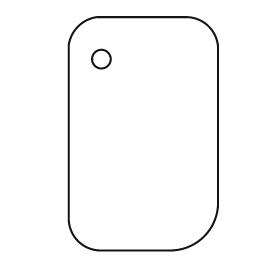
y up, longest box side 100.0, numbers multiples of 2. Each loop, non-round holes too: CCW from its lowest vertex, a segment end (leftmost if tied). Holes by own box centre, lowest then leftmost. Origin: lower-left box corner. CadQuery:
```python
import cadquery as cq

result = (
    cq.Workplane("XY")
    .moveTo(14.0, 0.0)
    .lineTo(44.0, 0.0)
    .threePointArc((58.0, 6.0), (64.0, 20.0))
    .lineTo(64.0, 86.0)
    .threePointArc((60.0, 96.0), (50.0, 100.0))
    .lineTo(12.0, 100.0)
    .threePointArc((4.0, 96.0), (0.0, 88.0))
    .lineTo(0.0, 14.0)
    .threePointArc((4.0, 4.0), (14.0, 0.0))
    .close()
    .moveTo(14.0, 82.0)
    .circle(4.0)
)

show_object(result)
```